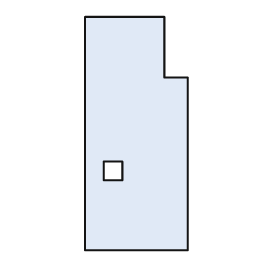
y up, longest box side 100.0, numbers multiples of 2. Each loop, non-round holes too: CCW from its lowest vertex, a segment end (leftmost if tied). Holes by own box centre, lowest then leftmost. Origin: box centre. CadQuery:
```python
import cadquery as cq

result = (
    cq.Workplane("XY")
    .moveTo(-22.0, -50.0)
    .lineTo(22.0, -50.0)
    .lineTo(22.0, 24.0)
    .lineTo(12.0, 24.0)
    .lineTo(12.0, 50.0)
    .lineTo(-22.0, 50.0)
    .close()
    .moveTo(-14.0, -20.0)
    .lineTo(-6.0, -20.0)
    .lineTo(-6.0, -12.0)
    .lineTo(-14.0, -12.0)
    .close()
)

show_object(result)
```